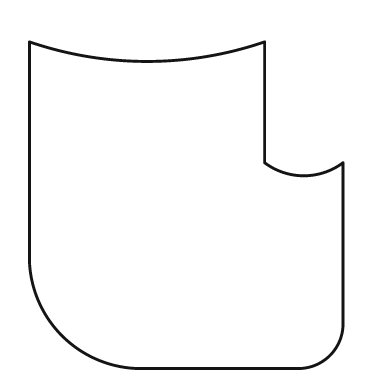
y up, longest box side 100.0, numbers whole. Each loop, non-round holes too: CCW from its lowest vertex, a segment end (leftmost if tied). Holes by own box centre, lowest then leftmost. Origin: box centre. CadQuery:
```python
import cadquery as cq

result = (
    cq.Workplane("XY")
    .moveTo(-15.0, -50.0)
    .lineTo(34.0, -50.0)
    .threePointArc((44.0, -46.0), (48.0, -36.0))
    .lineTo(48.0, 13.0)
    .threePointArc((36.0, 9.0), (24.0, 13.0))
    .lineTo(24.0, 50.0)
    .threePointArc((-12.0, 44.0), (-48.0, 50.0))
    .lineTo(-48.0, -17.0)
    .threePointArc((-38.0, -40.0), (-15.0, -50.0))
    .close()
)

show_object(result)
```